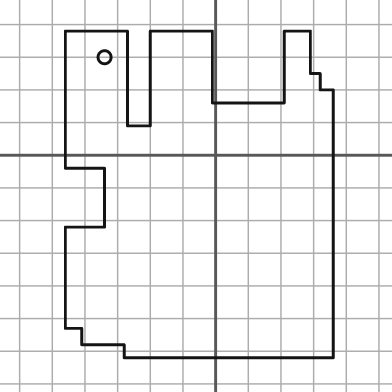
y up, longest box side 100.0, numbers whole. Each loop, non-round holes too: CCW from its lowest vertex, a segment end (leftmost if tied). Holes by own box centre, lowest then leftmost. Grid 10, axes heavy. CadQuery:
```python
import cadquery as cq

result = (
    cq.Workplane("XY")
    .moveTo(-28.0, -62.0)
    .lineTo(36.0, -62.0)
    .lineTo(36.0, 20.0)
    .lineTo(32.0, 20.0)
    .lineTo(32.0, 25.0)
    .lineTo(29.0, 25.0)
    .lineTo(29.0, 38.0)
    .lineTo(21.0, 38.0)
    .lineTo(21.0, 16.0)
    .lineTo(-1.0, 16.0)
    .lineTo(-1.0, 38.0)
    .lineTo(-20.0, 38.0)
    .lineTo(-20.0, 9.0)
    .lineTo(-27.0, 9.0)
    .lineTo(-27.0, 38.0)
    .lineTo(-46.0, 38.0)
    .lineTo(-46.0, -4.0)
    .lineTo(-34.0, -4.0)
    .lineTo(-34.0, -22.0)
    .lineTo(-46.0, -22.0)
    .lineTo(-46.0, -53.0)
    .lineTo(-41.0, -53.0)
    .lineTo(-41.0, -58.0)
    .lineTo(-28.0, -58.0)
    .close()
    .moveTo(-34.0, 30.0)
    .circle(2.0)
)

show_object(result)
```